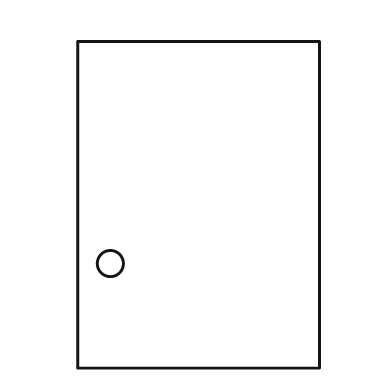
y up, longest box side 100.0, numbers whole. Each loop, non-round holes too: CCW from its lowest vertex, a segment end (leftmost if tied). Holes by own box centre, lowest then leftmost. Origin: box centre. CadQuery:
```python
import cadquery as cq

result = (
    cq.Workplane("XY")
    .moveTo(-37.0, -50.0)
    .lineTo(37.0, -50.0)
    .lineTo(37.0, 50.0)
    .lineTo(-37.0, 50.0)
    .close()
    .moveTo(-27.0, -18.0)
    .circle(4.0)
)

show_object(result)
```